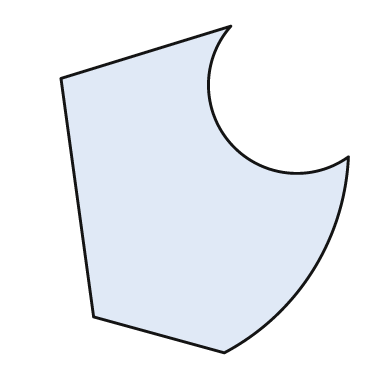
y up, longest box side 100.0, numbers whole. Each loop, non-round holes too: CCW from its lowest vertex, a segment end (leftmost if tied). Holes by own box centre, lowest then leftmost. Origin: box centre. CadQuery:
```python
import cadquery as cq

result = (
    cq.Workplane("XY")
    .moveTo(6.0, -50.0)
    .threePointArc((33.0, -25.0), (44.0, 10.0))
    .threePointArc((8.0, 14.0), (8.0, 50.0))
    .lineTo(-44.0, 34.0)
    .lineTo(-34.0, -39.0)
    .close()
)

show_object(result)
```